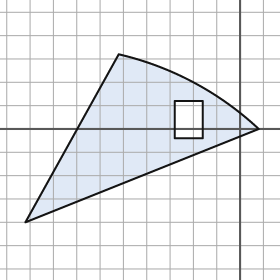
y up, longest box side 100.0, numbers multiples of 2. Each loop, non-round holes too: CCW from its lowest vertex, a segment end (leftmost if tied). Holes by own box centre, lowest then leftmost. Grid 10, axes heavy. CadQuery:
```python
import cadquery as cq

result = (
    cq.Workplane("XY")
    .moveTo(-92.0, -40.0)
    .lineTo(8.0, 0.0)
    .threePointArc((-20.0, 20.0), (-52.0, 32.0))
    .close()
    .moveTo(-28.0, -4.0)
    .lineTo(-16.0, -4.0)
    .lineTo(-16.0, 12.0)
    .lineTo(-28.0, 12.0)
    .close()
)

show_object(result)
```